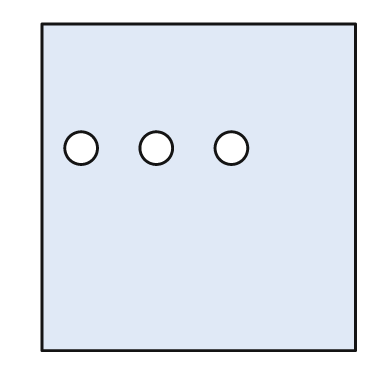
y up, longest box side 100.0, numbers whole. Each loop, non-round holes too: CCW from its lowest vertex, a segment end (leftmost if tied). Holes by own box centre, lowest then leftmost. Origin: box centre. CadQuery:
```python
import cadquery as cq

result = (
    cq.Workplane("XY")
    .moveTo(-48.0, -50.0)
    .lineTo(48.0, -50.0)
    .lineTo(48.0, 50.0)
    .lineTo(-48.0, 50.0)
    .close()
    .moveTo(-36.0, 12.0)
    .circle(5.0)
    .moveTo(-13.0, 12.0)
    .circle(5.0)
    .moveTo(10.0, 12.0)
    .circle(5.0)
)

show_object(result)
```